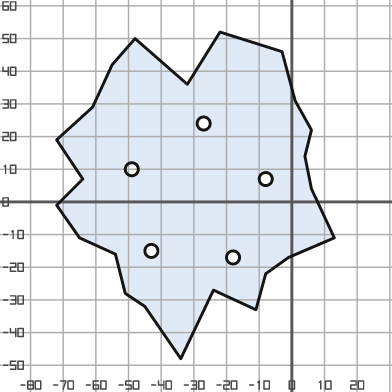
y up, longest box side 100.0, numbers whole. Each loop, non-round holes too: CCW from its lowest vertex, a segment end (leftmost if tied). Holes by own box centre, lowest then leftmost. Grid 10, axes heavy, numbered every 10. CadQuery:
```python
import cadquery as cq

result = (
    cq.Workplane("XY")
    .moveTo(-34.0, -48.0)
    .lineTo(-24.0, -27.0)
    .lineTo(-11.0, -33.0)
    .lineTo(-8.0, -22.0)
    .lineTo(-1.0, -17.0)
    .lineTo(13.0, -11.0)
    .lineTo(6.0, 4.0)
    .lineTo(4.0, 14.0)
    .lineTo(6.0, 22.0)
    .lineTo(1.0, 31.0)
    .lineTo(-3.0, 46.0)
    .lineTo(-22.0, 52.0)
    .lineTo(-32.0, 36.0)
    .lineTo(-48.0, 50.0)
    .lineTo(-55.0, 42.0)
    .lineTo(-61.0, 29.0)
    .lineTo(-72.0, 19.0)
    .lineTo(-64.0, 7.0)
    .lineTo(-72.0, -1.0)
    .lineTo(-65.0, -11.0)
    .lineTo(-54.0, -16.0)
    .lineTo(-51.0, -28.0)
    .lineTo(-45.0, -32.0)
    .close()
    .moveTo(-18.0, -17.0)
    .circle(2.0)
    .moveTo(-43.0, -15.0)
    .circle(2.0)
    .moveTo(-8.0, 7.0)
    .circle(2.0)
    .moveTo(-49.0, 10.0)
    .circle(2.0)
    .moveTo(-27.0, 24.0)
    .circle(2.0)
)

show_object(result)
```